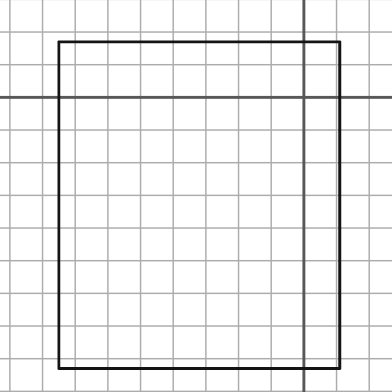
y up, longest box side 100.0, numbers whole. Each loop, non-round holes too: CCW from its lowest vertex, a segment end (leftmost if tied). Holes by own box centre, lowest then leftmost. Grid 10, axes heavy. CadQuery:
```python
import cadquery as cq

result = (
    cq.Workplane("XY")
    .moveTo(-75.0, -83.0)
    .lineTo(11.0, -83.0)
    .lineTo(11.0, 17.0)
    .lineTo(-75.0, 17.0)
    .close()
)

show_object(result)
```